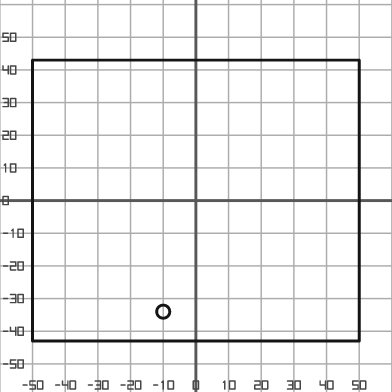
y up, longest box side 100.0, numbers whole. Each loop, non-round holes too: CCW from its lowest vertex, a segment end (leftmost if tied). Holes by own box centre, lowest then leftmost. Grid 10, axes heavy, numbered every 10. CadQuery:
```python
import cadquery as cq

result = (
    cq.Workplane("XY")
    .moveTo(-50.0, -43.0)
    .lineTo(50.0, -43.0)
    .lineTo(50.0, 43.0)
    .lineTo(-50.0, 43.0)
    .close()
    .moveTo(-10.0, -34.0)
    .circle(2.0)
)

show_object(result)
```